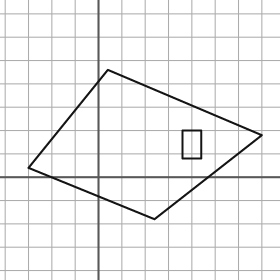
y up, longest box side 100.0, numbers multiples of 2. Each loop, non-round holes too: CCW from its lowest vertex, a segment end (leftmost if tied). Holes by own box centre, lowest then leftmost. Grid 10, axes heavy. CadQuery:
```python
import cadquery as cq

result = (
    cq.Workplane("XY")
    .moveTo(24.0, -18.0)
    .lineTo(70.0, 18.0)
    .lineTo(4.0, 46.0)
    .lineTo(-30.0, 4.0)
    .close()
    .moveTo(36.0, 8.0)
    .lineTo(44.0, 8.0)
    .lineTo(44.0, 20.0)
    .lineTo(36.0, 20.0)
    .close()
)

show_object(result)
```